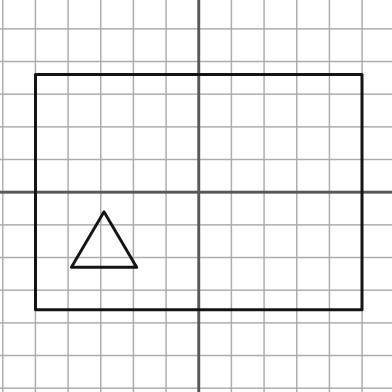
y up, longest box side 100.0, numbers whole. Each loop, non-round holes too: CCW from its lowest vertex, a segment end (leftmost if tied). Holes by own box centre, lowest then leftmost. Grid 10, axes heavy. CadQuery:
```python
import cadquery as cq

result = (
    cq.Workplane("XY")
    .moveTo(-50.0, -36.0)
    .lineTo(50.0, -36.0)
    .lineTo(50.0, 36.0)
    .lineTo(-50.0, 36.0)
    .close()
    .moveTo(-39.0, -23.0)
    .lineTo(-19.0, -23.0)
    .lineTo(-29.0, -6.0)
    .close()
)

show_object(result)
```